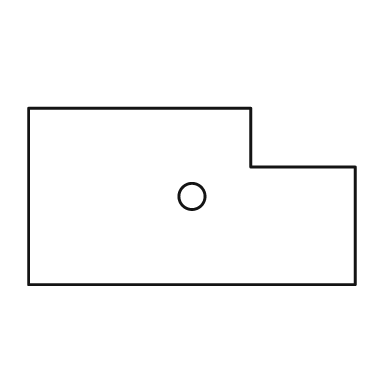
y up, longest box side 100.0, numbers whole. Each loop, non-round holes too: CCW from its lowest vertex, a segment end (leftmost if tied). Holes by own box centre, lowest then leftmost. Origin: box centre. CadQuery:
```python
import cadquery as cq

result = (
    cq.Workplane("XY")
    .moveTo(-50.0, -27.0)
    .lineTo(50.0, -27.0)
    .lineTo(50.0, 9.0)
    .lineTo(18.0, 9.0)
    .lineTo(18.0, 27.0)
    .lineTo(-50.0, 27.0)
    .close()
    .moveTo(0.0, 0.0)
    .circle(4.0)
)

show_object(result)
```